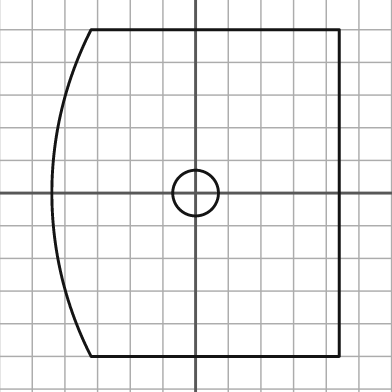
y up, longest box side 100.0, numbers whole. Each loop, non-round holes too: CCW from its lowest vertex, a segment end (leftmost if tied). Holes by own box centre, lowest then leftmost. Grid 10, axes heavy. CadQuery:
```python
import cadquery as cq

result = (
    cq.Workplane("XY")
    .moveTo(-32.0, -50.0)
    .lineTo(44.0, -50.0)
    .lineTo(44.0, 50.0)
    .lineTo(-32.0, 50.0)
    .threePointArc((-44.0, 0.0), (-32.0, -50.0))
    .close()
    .moveTo(0.0, 0.0)
    .circle(7.0)
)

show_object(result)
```